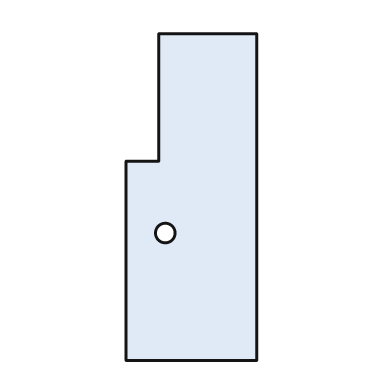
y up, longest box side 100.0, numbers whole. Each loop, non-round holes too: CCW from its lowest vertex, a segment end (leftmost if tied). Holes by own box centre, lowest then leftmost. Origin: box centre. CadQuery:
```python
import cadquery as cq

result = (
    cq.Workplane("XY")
    .moveTo(-20.0, -50.0)
    .lineTo(20.0, -50.0)
    .lineTo(20.0, 50.0)
    .lineTo(-10.0, 50.0)
    .lineTo(-10.0, 11.0)
    .lineTo(-20.0, 11.0)
    .close()
    .moveTo(-8.0, -11.0)
    .circle(3.0)
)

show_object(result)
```